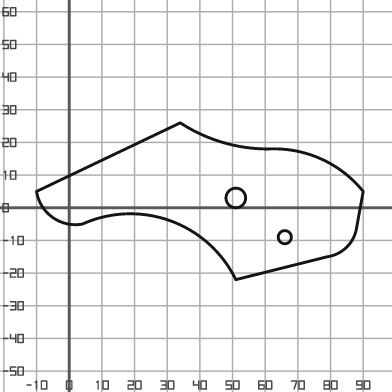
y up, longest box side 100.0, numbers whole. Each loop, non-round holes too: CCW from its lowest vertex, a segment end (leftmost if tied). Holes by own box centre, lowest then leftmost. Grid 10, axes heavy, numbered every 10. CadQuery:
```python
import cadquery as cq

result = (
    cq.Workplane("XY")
    .moveTo(51.0, -22.0)
    .lineTo(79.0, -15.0)
    .threePointArc((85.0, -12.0), (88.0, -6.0))
    .lineTo(90.0, 5.0)
    .threePointArc((77.0, 15.0), (61.0, 18.0))
    .threePointArc((47.0, 20.0), (34.0, 26.0))
    .lineTo(-10.0, 5.0)
    .threePointArc((-5.0, -3.0), (4.0, -5.0))
    .threePointArc((31.0, -4.0), (51.0, -22.0))
    .close()
    .moveTo(66.0, -9.0)
    .circle(2.0)
    .moveTo(51.0, 3.0)
    .circle(3.0)
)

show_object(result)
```